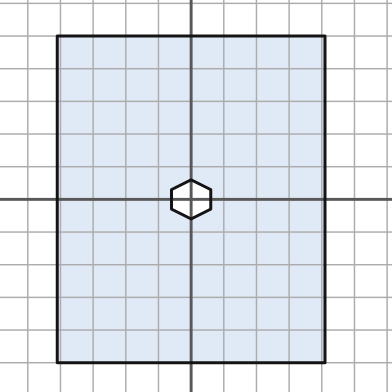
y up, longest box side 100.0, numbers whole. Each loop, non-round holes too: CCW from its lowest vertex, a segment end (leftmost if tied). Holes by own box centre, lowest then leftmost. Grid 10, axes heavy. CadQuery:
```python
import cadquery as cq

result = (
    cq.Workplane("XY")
    .moveTo(-41.0, -50.0)
    .lineTo(41.0, -50.0)
    .lineTo(41.0, 50.0)
    .lineTo(-41.0, 50.0)
    .close()
    .moveTo(0.0, -6.0)
    .lineTo(6.0, -3.0)
    .lineTo(6.0, 3.0)
    .lineTo(0.0, 6.0)
    .lineTo(-6.0, 3.0)
    .lineTo(-6.0, -3.0)
    .close()
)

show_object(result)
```